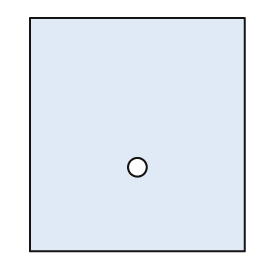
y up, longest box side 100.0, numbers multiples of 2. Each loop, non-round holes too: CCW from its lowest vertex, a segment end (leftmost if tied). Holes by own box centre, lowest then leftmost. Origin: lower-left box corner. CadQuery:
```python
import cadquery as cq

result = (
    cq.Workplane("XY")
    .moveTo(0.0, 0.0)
    .lineTo(92.0, 0.0)
    .lineTo(92.0, 100.0)
    .lineTo(0.0, 100.0)
    .close()
    .moveTo(46.0, 36.0)
    .circle(4.0)
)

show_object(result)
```